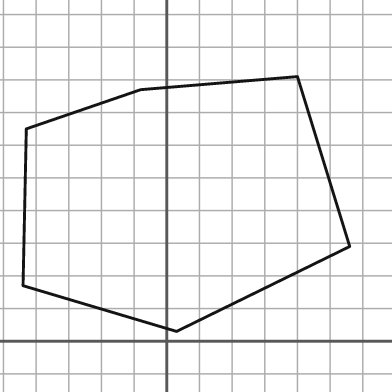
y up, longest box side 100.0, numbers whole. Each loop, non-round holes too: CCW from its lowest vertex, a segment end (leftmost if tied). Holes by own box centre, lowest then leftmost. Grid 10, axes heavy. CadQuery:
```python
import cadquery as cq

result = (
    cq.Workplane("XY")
    .moveTo(3.0, 3.0)
    .lineTo(56.0, 29.0)
    .lineTo(40.0, 81.0)
    .lineTo(-8.0, 77.0)
    .lineTo(-43.0, 65.0)
    .lineTo(-44.0, 17.0)
    .close()
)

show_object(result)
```